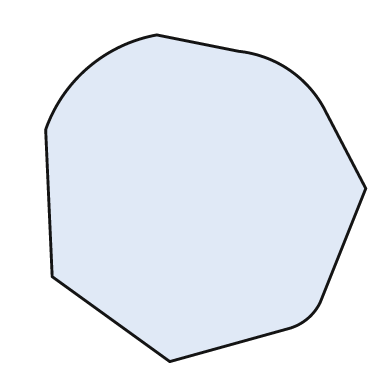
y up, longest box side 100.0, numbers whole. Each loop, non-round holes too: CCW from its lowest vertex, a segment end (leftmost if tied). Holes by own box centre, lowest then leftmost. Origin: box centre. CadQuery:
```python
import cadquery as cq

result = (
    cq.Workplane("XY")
    .moveTo(-11.0, -50.0)
    .lineTo(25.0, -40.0)
    .threePointArc((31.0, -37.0), (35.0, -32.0))
    .lineTo(49.0, 3.0)
    .lineTo(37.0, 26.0)
    .threePointArc((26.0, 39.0), (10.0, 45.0))
    .lineTo(-15.0, 50.0)
    .threePointArc((-36.0, 40.0), (-49.0, 21.0))
    .lineTo(-47.0, -24.0)
    .close()
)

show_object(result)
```